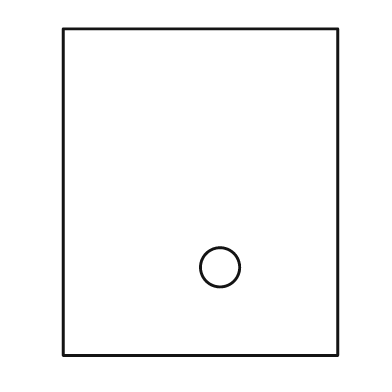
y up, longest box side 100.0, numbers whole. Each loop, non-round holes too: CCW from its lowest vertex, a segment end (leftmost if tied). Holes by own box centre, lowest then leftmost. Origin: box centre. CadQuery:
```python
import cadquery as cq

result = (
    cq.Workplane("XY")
    .moveTo(-42.0, -50.0)
    .lineTo(42.0, -50.0)
    .lineTo(42.0, 50.0)
    .lineTo(-42.0, 50.0)
    .close()
    .moveTo(6.0, -23.0)
    .circle(6.0)
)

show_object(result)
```